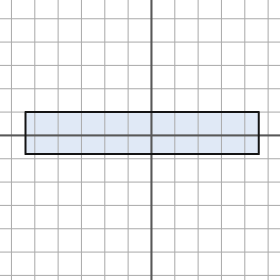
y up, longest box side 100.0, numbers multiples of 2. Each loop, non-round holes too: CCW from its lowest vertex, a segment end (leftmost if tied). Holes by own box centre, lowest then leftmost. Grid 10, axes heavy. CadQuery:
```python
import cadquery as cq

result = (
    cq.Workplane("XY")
    .moveTo(-54.0, -8.0)
    .lineTo(46.0, -8.0)
    .lineTo(46.0, 10.0)
    .lineTo(-54.0, 10.0)
    .close()
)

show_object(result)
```